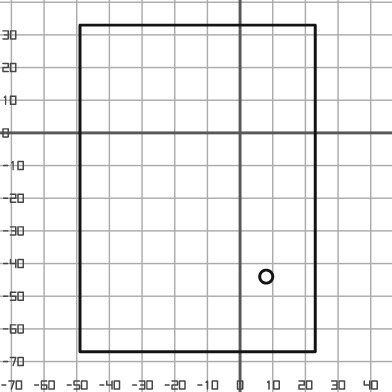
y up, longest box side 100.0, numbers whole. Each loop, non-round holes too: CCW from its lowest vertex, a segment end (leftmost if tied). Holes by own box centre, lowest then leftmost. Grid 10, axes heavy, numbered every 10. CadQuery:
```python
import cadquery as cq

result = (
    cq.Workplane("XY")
    .moveTo(-49.0, -67.0)
    .lineTo(23.0, -67.0)
    .lineTo(23.0, 33.0)
    .lineTo(-49.0, 33.0)
    .close()
    .moveTo(8.0, -44.0)
    .circle(2.0)
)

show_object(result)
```